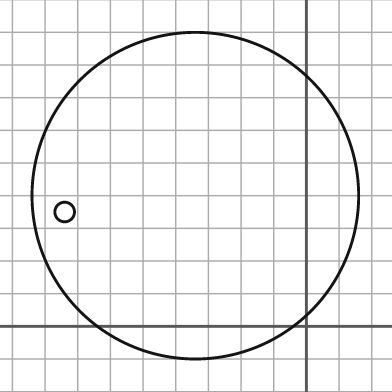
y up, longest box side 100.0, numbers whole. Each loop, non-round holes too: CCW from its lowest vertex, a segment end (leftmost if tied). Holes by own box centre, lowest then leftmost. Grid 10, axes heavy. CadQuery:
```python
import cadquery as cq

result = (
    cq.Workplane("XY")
    .moveTo(-34.0, 40.0)
    .circle(50.0)
    .moveTo(-74.0, 35.0)
    .circle(3.0)
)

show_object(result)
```